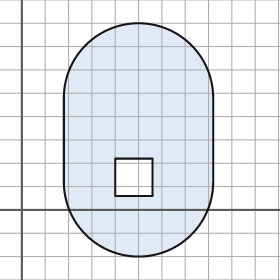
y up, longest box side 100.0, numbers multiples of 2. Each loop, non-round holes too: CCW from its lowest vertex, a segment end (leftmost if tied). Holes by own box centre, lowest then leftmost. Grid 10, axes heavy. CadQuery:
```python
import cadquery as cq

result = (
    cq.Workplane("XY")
    .moveTo(18.0, 12.0)
    .threePointArc((50.0, -20.0), (82.0, 12.0))
    .lineTo(82.0, 48.0)
    .threePointArc((50.0, 80.0), (18.0, 48.0))
    .close()
    .moveTo(40.0, 6.0)
    .lineTo(56.0, 6.0)
    .lineTo(56.0, 22.0)
    .lineTo(40.0, 22.0)
    .close()
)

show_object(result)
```